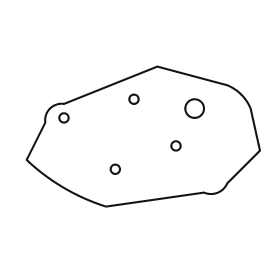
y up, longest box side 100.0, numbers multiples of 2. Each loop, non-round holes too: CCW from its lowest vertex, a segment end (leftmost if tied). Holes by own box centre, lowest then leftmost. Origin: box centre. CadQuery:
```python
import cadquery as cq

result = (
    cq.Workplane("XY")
    .moveTo(-16.0, -30.0)
    .lineTo(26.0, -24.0)
    .threePointArc((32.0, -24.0), (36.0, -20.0))
    .lineTo(50.0, -6.0)
    .lineTo(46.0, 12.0)
    .threePointArc((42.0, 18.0), (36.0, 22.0))
    .lineTo(6.0, 30.0)
    .lineTo(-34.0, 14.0)
    .threePointArc((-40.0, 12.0), (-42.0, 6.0))
    .lineTo(-50.0, -10.0)
    .threePointArc((-34.0, -22.0), (-16.0, -30.0))
    .close()
    .moveTo(-12.0, -14.0)
    .circle(2.0)
    .moveTo(14.0, -4.0)
    .circle(2.0)
    .moveTo(-34.0, 8.0)
    .circle(2.0)
    .moveTo(22.0, 12.0)
    .circle(4.0)
    .moveTo(-4.0, 16.0)
    .circle(2.0)
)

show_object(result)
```